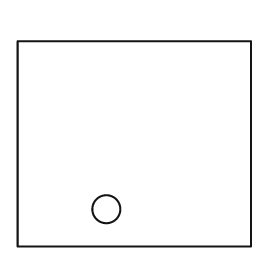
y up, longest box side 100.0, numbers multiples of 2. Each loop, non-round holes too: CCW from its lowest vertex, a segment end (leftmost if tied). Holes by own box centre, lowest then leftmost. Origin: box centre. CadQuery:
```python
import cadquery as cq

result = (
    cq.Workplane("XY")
    .moveTo(-50.0, -44.0)
    .lineTo(50.0, -44.0)
    .lineTo(50.0, 44.0)
    .lineTo(-50.0, 44.0)
    .close()
    .moveTo(-12.0, -28.0)
    .circle(6.0)
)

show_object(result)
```